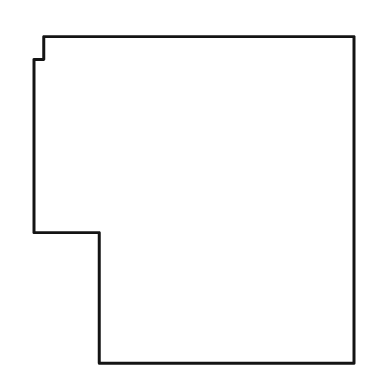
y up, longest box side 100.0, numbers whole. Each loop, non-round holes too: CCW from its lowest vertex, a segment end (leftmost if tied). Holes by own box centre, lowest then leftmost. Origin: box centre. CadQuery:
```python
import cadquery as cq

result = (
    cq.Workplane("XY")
    .moveTo(-29.0, -50.0)
    .lineTo(49.0, -50.0)
    .lineTo(49.0, 50.0)
    .lineTo(-46.0, 50.0)
    .lineTo(-46.0, 43.0)
    .lineTo(-49.0, 43.0)
    .lineTo(-49.0, -10.0)
    .lineTo(-29.0, -10.0)
    .close()
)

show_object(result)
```